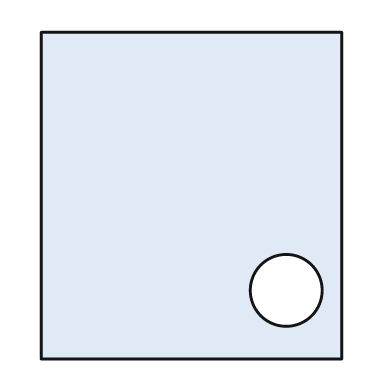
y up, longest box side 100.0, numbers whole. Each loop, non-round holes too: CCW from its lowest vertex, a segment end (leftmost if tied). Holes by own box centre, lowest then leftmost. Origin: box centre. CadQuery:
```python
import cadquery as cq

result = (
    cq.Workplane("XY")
    .moveTo(-46.0, -50.0)
    .lineTo(46.0, -50.0)
    .lineTo(46.0, 50.0)
    .lineTo(-46.0, 50.0)
    .close()
    .moveTo(29.0, -29.0)
    .circle(11.0)
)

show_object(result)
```